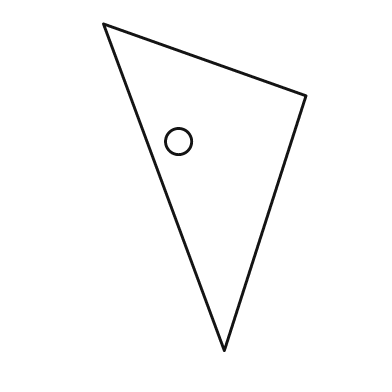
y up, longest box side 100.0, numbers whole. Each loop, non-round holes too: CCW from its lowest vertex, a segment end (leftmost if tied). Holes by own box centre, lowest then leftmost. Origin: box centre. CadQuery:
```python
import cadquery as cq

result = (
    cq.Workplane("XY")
    .moveTo(6.0, -50.0)
    .lineTo(31.0, 28.0)
    .lineTo(-31.0, 50.0)
    .close()
    .moveTo(-8.0, 14.0)
    .circle(4.0)
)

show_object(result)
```